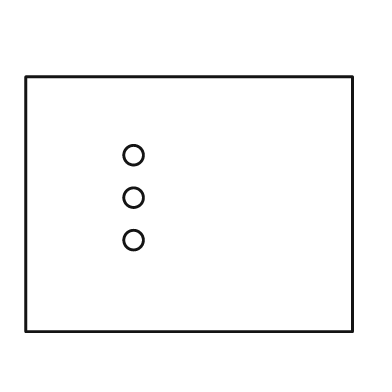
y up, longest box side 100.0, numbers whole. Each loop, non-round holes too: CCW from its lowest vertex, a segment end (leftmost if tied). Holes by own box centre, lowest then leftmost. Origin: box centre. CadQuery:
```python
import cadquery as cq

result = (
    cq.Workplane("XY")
    .moveTo(-50.0, -39.0)
    .lineTo(50.0, -39.0)
    .lineTo(50.0, 39.0)
    .lineTo(-50.0, 39.0)
    .close()
    .moveTo(-17.0, -11.0)
    .circle(3.0)
    .moveTo(-17.0, 2.0)
    .circle(3.0)
    .moveTo(-17.0, 15.0)
    .circle(3.0)
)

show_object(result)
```